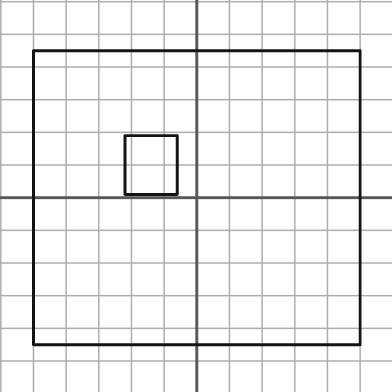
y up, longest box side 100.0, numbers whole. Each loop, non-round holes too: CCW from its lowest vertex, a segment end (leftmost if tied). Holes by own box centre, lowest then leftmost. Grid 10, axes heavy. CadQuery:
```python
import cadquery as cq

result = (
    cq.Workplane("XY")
    .moveTo(-50.0, -45.0)
    .lineTo(50.0, -45.0)
    .lineTo(50.0, 45.0)
    .lineTo(-50.0, 45.0)
    .close()
    .moveTo(-22.0, 1.0)
    .lineTo(-6.0, 1.0)
    .lineTo(-6.0, 19.0)
    .lineTo(-22.0, 19.0)
    .close()
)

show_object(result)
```